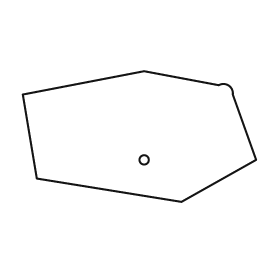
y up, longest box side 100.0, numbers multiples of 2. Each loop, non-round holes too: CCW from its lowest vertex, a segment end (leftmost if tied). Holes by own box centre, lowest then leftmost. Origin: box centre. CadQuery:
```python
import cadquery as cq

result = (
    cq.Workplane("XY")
    .moveTo(18.0, -28.0)
    .lineTo(50.0, -10.0)
    .lineTo(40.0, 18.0)
    .threePointArc((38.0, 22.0), (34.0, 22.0))
    .lineTo(2.0, 28.0)
    .lineTo(-50.0, 18.0)
    .lineTo(-44.0, -18.0)
    .close()
    .moveTo(2.0, -10.0)
    .circle(2.0)
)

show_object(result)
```